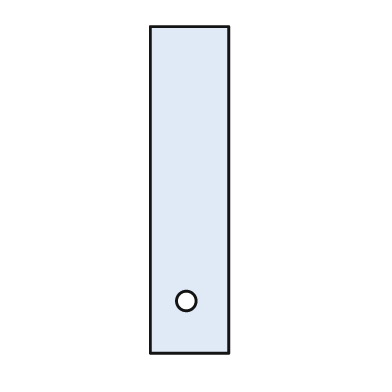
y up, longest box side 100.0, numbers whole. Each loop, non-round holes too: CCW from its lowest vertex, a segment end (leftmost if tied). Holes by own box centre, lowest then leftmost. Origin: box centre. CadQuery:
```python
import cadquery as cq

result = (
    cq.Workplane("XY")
    .moveTo(-12.0, -50.0)
    .lineTo(12.0, -50.0)
    .lineTo(12.0, 50.0)
    .lineTo(-12.0, 50.0)
    .close()
    .moveTo(-1.0, -34.0)
    .circle(3.0)
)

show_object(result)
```